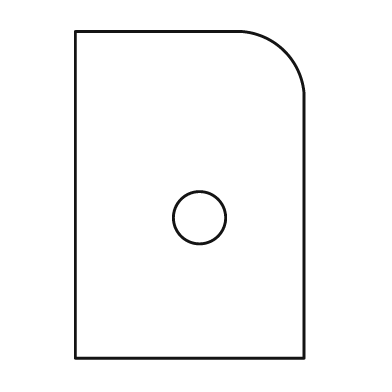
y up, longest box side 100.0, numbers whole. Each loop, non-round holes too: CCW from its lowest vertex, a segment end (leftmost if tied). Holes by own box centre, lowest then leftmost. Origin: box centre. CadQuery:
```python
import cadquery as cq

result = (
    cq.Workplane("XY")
    .moveTo(-35.0, -50.0)
    .lineTo(35.0, -50.0)
    .lineTo(35.0, 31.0)
    .threePointArc((29.0, 44.0), (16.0, 50.0))
    .lineTo(-35.0, 50.0)
    .close()
    .moveTo(3.0, -7.0)
    .circle(8.0)
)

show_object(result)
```